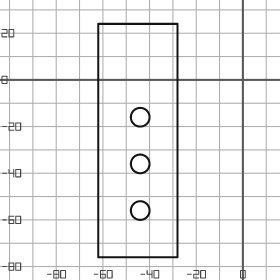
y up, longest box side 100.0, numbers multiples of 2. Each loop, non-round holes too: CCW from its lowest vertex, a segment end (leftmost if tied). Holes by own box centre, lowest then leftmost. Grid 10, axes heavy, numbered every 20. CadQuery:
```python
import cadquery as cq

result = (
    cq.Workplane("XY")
    .moveTo(-62.0, -76.0)
    .lineTo(-28.0, -76.0)
    .lineTo(-28.0, 24.0)
    .lineTo(-62.0, 24.0)
    .close()
    .moveTo(-44.0, -56.0)
    .circle(4.0)
    .moveTo(-44.0, -36.0)
    .circle(4.0)
    .moveTo(-44.0, -16.0)
    .circle(4.0)
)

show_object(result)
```